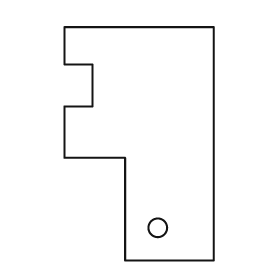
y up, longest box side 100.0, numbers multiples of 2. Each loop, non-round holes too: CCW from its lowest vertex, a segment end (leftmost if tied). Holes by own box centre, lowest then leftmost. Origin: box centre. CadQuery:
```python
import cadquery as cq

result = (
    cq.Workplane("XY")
    .moveTo(-6.0, -50.0)
    .lineTo(32.0, -50.0)
    .lineTo(32.0, 50.0)
    .lineTo(-32.0, 50.0)
    .lineTo(-32.0, 34.0)
    .lineTo(-20.0, 34.0)
    .lineTo(-20.0, 16.0)
    .lineTo(-32.0, 16.0)
    .lineTo(-32.0, -6.0)
    .lineTo(-6.0, -6.0)
    .close()
    .moveTo(8.0, -36.0)
    .circle(4.0)
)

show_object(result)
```